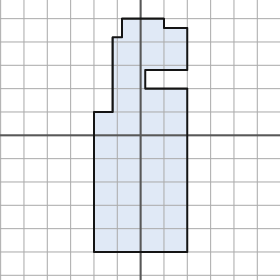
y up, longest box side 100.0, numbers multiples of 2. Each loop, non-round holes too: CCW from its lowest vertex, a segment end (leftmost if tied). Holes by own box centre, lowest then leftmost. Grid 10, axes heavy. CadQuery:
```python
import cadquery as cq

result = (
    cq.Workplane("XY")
    .moveTo(-20.0, -50.0)
    .lineTo(20.0, -50.0)
    .lineTo(20.0, 20.0)
    .lineTo(2.0, 20.0)
    .lineTo(2.0, 28.0)
    .lineTo(20.0, 28.0)
    .lineTo(20.0, 46.0)
    .lineTo(10.0, 46.0)
    .lineTo(10.0, 50.0)
    .lineTo(-8.0, 50.0)
    .lineTo(-8.0, 42.0)
    .lineTo(-12.0, 42.0)
    .lineTo(-12.0, 10.0)
    .lineTo(-20.0, 10.0)
    .close()
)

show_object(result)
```